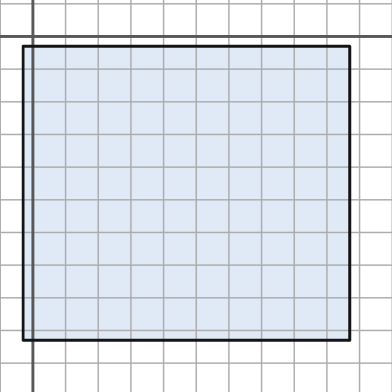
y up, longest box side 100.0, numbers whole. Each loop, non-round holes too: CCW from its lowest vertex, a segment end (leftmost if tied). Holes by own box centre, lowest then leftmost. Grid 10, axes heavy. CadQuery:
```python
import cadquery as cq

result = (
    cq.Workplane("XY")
    .moveTo(-3.0, -93.0)
    .lineTo(97.0, -93.0)
    .lineTo(97.0, -3.0)
    .lineTo(-3.0, -3.0)
    .close()
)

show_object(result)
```